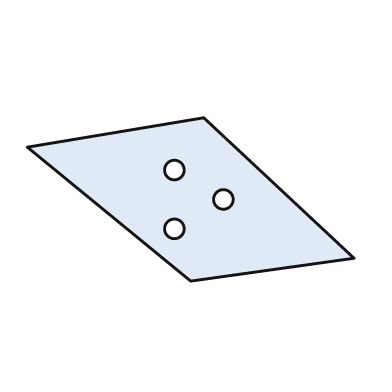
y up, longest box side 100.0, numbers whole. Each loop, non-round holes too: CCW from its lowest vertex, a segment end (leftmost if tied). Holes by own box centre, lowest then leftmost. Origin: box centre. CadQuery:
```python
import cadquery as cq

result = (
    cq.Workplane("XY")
    .moveTo(0.0, -25.0)
    .lineTo(50.0, -18.0)
    .lineTo(4.0, 25.0)
    .lineTo(-50.0, 16.0)
    .close()
    .moveTo(-5.0, -9.0)
    .circle(3.0)
    .moveTo(10.0, 0.0)
    .circle(3.0)
    .moveTo(-5.0, 9.0)
    .circle(3.0)
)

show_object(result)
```